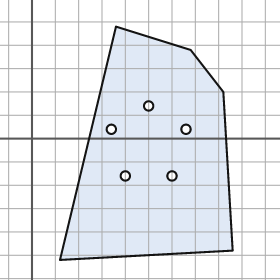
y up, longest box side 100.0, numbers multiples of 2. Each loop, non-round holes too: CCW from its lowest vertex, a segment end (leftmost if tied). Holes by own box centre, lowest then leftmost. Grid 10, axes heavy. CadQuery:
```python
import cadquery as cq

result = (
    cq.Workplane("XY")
    .moveTo(12.0, -52.0)
    .lineTo(86.0, -48.0)
    .lineTo(82.0, 20.0)
    .lineTo(68.0, 38.0)
    .lineTo(36.0, 48.0)
    .close()
    .moveTo(40.0, -16.0)
    .circle(2.0)
    .moveTo(60.0, -16.0)
    .circle(2.0)
    .moveTo(34.0, 4.0)
    .circle(2.0)
    .moveTo(66.0, 4.0)
    .circle(2.0)
    .moveTo(50.0, 14.0)
    .circle(2.0)
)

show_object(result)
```